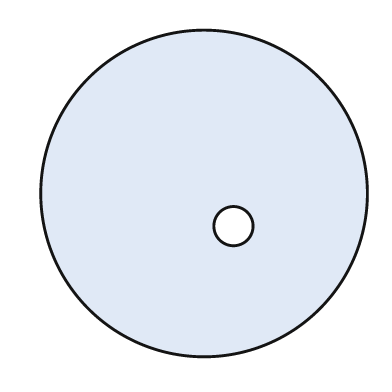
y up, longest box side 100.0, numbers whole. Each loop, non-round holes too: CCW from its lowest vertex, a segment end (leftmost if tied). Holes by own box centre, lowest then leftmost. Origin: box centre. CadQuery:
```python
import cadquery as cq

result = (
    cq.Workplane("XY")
    .moveTo(0.0, 0.0)
    .circle(50.0)
    .moveTo(9.0, -10.0)
    .circle(6.0)
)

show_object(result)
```